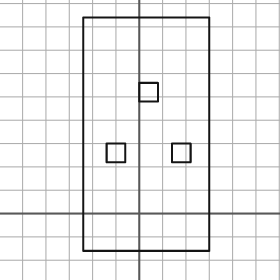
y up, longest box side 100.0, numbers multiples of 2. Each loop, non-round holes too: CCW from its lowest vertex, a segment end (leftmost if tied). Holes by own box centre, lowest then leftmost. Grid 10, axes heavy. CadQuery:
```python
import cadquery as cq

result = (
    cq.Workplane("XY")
    .moveTo(-24.0, -16.0)
    .lineTo(30.0, -16.0)
    .lineTo(30.0, 84.0)
    .lineTo(-24.0, 84.0)
    .close()
    .moveTo(-14.0, 22.0)
    .lineTo(-6.0, 22.0)
    .lineTo(-6.0, 30.0)
    .lineTo(-14.0, 30.0)
    .close()
    .moveTo(14.0, 22.0)
    .lineTo(22.0, 22.0)
    .lineTo(22.0, 30.0)
    .lineTo(14.0, 30.0)
    .close()
    .moveTo(0.0, 48.0)
    .lineTo(8.0, 48.0)
    .lineTo(8.0, 56.0)
    .lineTo(0.0, 56.0)
    .close()
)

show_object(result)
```